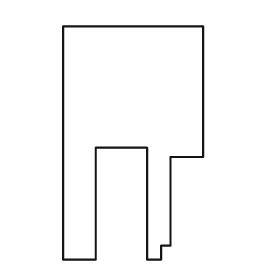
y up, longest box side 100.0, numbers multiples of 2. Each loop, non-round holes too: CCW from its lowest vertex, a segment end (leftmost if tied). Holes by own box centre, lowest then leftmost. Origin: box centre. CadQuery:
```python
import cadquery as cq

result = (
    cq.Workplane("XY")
    .moveTo(-30.0, -50.0)
    .lineTo(-16.0, -50.0)
    .lineTo(-16.0, -2.0)
    .lineTo(6.0, -2.0)
    .lineTo(6.0, -50.0)
    .lineTo(12.0, -50.0)
    .lineTo(12.0, -44.0)
    .lineTo(16.0, -44.0)
    .lineTo(16.0, -6.0)
    .lineTo(30.0, -6.0)
    .lineTo(30.0, 50.0)
    .lineTo(-30.0, 50.0)
    .close()
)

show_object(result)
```